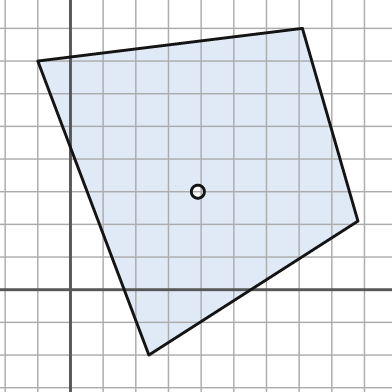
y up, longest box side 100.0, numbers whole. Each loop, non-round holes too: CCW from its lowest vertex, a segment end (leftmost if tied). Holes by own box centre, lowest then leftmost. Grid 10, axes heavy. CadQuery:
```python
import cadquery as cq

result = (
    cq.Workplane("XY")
    .moveTo(24.0, -20.0)
    .lineTo(88.0, 21.0)
    .lineTo(71.0, 80.0)
    .lineTo(-10.0, 70.0)
    .close()
    .moveTo(39.0, 30.0)
    .circle(2.0)
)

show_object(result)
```